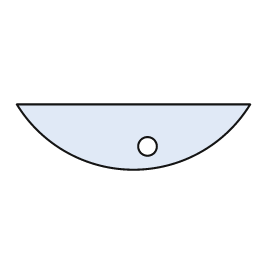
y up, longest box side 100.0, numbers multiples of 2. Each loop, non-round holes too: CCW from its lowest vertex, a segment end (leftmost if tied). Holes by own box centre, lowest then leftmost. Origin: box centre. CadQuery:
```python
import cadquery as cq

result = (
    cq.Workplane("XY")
    .moveTo(-50.0, 14.0)
    .threePointArc((0.0, -14.0), (50.0, 14.0))
    .close()
    .moveTo(6.0, -4.0)
    .circle(4.0)
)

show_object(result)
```